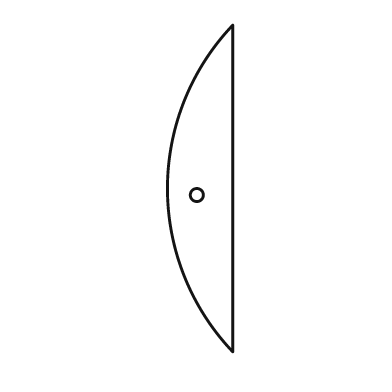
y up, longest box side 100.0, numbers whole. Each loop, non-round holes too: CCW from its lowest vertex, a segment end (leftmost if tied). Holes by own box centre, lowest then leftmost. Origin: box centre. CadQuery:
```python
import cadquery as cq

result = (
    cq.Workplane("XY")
    .moveTo(10.0, -50.0)
    .lineTo(10.0, 50.0)
    .threePointArc((-10.0, 0.0), (10.0, -50.0))
    .close()
    .moveTo(-1.0, -2.0)
    .circle(2.0)
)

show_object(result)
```